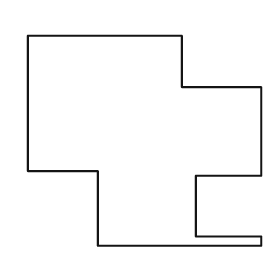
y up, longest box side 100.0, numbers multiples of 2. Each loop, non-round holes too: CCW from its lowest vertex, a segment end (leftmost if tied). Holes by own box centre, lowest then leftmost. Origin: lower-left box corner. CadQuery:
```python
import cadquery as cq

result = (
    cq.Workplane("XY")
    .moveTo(30.0, 0.0)
    .lineTo(100.0, 0.0)
    .lineTo(100.0, 4.0)
    .lineTo(72.0, 4.0)
    .lineTo(72.0, 30.0)
    .lineTo(100.0, 30.0)
    .lineTo(100.0, 68.0)
    .lineTo(66.0, 68.0)
    .lineTo(66.0, 90.0)
    .lineTo(0.0, 90.0)
    .lineTo(0.0, 32.0)
    .lineTo(30.0, 32.0)
    .close()
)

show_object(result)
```